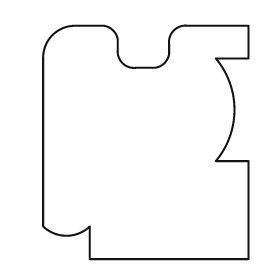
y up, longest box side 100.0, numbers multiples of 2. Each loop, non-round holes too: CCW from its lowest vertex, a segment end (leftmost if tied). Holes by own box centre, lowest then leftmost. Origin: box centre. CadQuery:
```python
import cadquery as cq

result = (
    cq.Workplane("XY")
    .moveTo(-24.0, -50.0)
    .lineTo(44.0, -50.0)
    .lineTo(44.0, -8.0)
    .lineTo(30.0, -8.0)
    .threePointArc((38.0, 14.0), (30.0, 36.0))
    .lineTo(44.0, 36.0)
    .lineTo(44.0, 50.0)
    .lineTo(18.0, 50.0)
    .threePointArc((12.0, 48.0), (10.0, 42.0))
    .lineTo(10.0, 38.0)
    .threePointArc((8.0, 34.0), (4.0, 32.0))
    .lineTo(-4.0, 32.0)
    .threePointArc((-10.0, 34.0), (-12.0, 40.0))
    .lineTo(-12.0, 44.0)
    .threePointArc((-14.0, 48.0), (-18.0, 50.0))
    .lineTo(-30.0, 50.0)
    .threePointArc((-40.0, 46.0), (-44.0, 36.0))
    .lineTo(-44.0, -36.0)
    .threePointArc((-34.0, -40.0), (-24.0, -36.0))
    .close()
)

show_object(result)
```